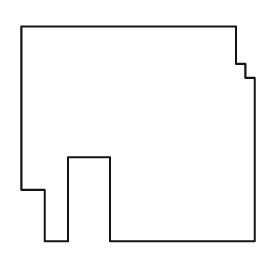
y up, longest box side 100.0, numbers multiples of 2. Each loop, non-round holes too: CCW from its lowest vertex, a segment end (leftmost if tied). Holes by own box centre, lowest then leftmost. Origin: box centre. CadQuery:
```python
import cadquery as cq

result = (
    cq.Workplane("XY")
    .moveTo(-40.0, -46.0)
    .lineTo(-30.0, -46.0)
    .lineTo(-30.0, -10.0)
    .lineTo(-12.0, -10.0)
    .lineTo(-12.0, -46.0)
    .lineTo(50.0, -46.0)
    .lineTo(50.0, 24.0)
    .lineTo(46.0, 24.0)
    .lineTo(46.0, 30.0)
    .lineTo(42.0, 30.0)
    .lineTo(42.0, 46.0)
    .lineTo(-50.0, 46.0)
    .lineTo(-50.0, -24.0)
    .lineTo(-40.0, -24.0)
    .close()
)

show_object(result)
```